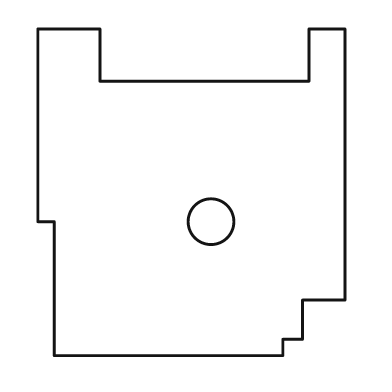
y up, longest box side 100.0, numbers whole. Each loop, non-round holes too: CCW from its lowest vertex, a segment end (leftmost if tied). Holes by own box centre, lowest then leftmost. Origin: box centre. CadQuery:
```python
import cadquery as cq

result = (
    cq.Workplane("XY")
    .moveTo(-42.0, -50.0)
    .lineTo(28.0, -50.0)
    .lineTo(28.0, -45.0)
    .lineTo(34.0, -45.0)
    .lineTo(34.0, -33.0)
    .lineTo(47.0, -33.0)
    .lineTo(47.0, 50.0)
    .lineTo(36.0, 50.0)
    .lineTo(36.0, 34.0)
    .lineTo(-28.0, 34.0)
    .lineTo(-28.0, 50.0)
    .lineTo(-47.0, 50.0)
    .lineTo(-47.0, -9.0)
    .lineTo(-42.0, -9.0)
    .close()
    .moveTo(6.0, -9.0)
    .circle(7.0)
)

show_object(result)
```